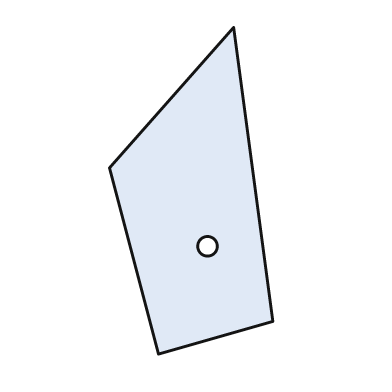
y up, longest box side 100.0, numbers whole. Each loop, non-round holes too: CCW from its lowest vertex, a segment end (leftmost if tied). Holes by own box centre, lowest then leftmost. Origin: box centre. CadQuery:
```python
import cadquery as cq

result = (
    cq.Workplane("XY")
    .moveTo(-10.0, -50.0)
    .lineTo(25.0, -40.0)
    .lineTo(13.0, 50.0)
    .lineTo(-25.0, 7.0)
    .close()
    .moveTo(5.0, -17.0)
    .circle(3.0)
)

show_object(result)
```